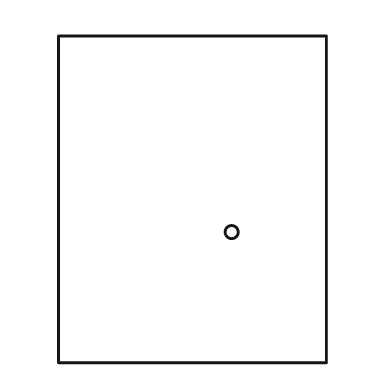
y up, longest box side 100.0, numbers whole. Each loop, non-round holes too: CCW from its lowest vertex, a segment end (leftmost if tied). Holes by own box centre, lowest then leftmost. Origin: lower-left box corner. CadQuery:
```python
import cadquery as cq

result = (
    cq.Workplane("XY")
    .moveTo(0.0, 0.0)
    .lineTo(82.0, 0.0)
    .lineTo(82.0, 100.0)
    .lineTo(0.0, 100.0)
    .close()
    .moveTo(53.0, 40.0)
    .circle(2.0)
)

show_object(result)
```